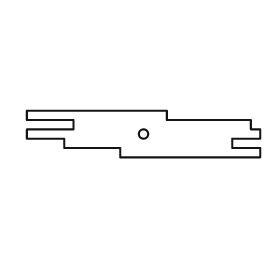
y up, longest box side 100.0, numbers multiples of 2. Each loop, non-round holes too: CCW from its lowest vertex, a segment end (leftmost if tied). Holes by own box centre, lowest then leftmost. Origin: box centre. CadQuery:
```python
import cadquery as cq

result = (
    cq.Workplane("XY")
    .moveTo(-10.0, -10.0)
    .lineTo(50.0, -10.0)
    .lineTo(50.0, -6.0)
    .lineTo(38.0, -6.0)
    .lineTo(38.0, -2.0)
    .lineTo(50.0, -2.0)
    .lineTo(50.0, 2.0)
    .lineTo(46.0, 2.0)
    .lineTo(46.0, 6.0)
    .lineTo(10.0, 6.0)
    .lineTo(10.0, 10.0)
    .lineTo(-50.0, 10.0)
    .lineTo(-50.0, 6.0)
    .lineTo(-30.0, 6.0)
    .lineTo(-30.0, 2.0)
    .lineTo(-50.0, 2.0)
    .lineTo(-50.0, -2.0)
    .lineTo(-34.0, -2.0)
    .lineTo(-34.0, -6.0)
    .lineTo(-10.0, -6.0)
    .close()
    .moveTo(0.0, 0.0)
    .circle(2.0)
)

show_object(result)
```